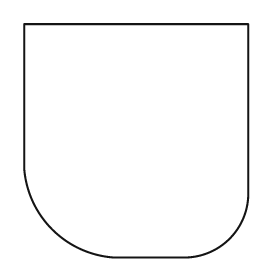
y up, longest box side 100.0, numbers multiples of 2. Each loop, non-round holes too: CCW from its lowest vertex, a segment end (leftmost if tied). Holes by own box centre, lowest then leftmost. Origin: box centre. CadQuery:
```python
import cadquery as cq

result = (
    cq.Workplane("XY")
    .moveTo(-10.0, -50.0)
    .lineTo(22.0, -50.0)
    .threePointArc((40.0, -42.0), (48.0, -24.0))
    .lineTo(48.0, 50.0)
    .lineTo(-48.0, 50.0)
    .lineTo(-48.0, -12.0)
    .threePointArc((-36.0, -38.0), (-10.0, -50.0))
    .close()
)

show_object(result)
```